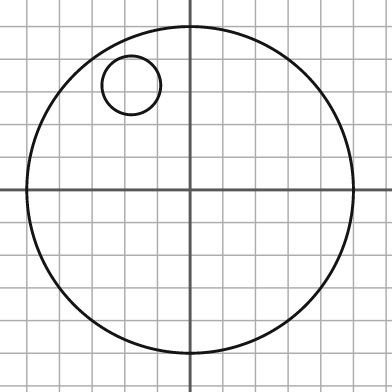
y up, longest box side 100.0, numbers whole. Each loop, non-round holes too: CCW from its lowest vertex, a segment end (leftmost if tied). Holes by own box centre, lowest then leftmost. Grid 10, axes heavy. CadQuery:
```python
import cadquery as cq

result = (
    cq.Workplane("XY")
    .moveTo(0.0, 0.0)
    .circle(50.0)
    .moveTo(-18.0, 32.0)
    .circle(9.0)
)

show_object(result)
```